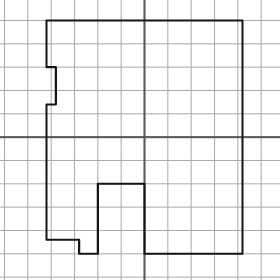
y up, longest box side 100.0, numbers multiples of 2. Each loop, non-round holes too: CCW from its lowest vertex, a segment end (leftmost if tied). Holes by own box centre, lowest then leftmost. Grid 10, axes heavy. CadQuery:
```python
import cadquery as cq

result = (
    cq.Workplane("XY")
    .moveTo(-28.0, -50.0)
    .lineTo(-20.0, -50.0)
    .lineTo(-20.0, -20.0)
    .lineTo(0.0, -20.0)
    .lineTo(0.0, -50.0)
    .lineTo(42.0, -50.0)
    .lineTo(42.0, 50.0)
    .lineTo(-42.0, 50.0)
    .lineTo(-42.0, 30.0)
    .lineTo(-38.0, 30.0)
    .lineTo(-38.0, 14.0)
    .lineTo(-42.0, 14.0)
    .lineTo(-42.0, -44.0)
    .lineTo(-28.0, -44.0)
    .close()
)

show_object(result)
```